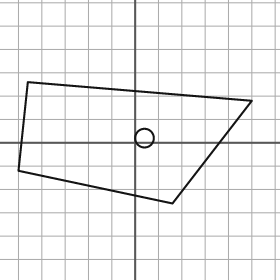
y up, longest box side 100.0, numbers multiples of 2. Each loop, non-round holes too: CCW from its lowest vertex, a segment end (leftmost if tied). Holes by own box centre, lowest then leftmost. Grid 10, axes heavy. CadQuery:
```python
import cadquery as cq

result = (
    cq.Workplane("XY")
    .moveTo(16.0, -26.0)
    .lineTo(50.0, 18.0)
    .lineTo(-46.0, 26.0)
    .lineTo(-50.0, -12.0)
    .close()
    .moveTo(4.0, 2.0)
    .circle(4.0)
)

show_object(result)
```